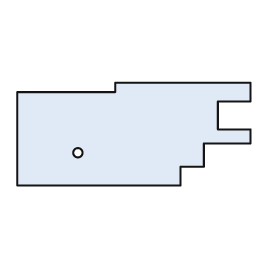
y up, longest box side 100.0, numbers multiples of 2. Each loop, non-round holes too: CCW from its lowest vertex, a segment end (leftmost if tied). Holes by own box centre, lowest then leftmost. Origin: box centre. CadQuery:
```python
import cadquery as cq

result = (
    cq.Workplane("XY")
    .moveTo(-50.0, -22.0)
    .lineTo(20.0, -22.0)
    .lineTo(20.0, -14.0)
    .lineTo(30.0, -14.0)
    .lineTo(30.0, -4.0)
    .lineTo(50.0, -4.0)
    .lineTo(50.0, 2.0)
    .lineTo(36.0, 2.0)
    .lineTo(36.0, 14.0)
    .lineTo(50.0, 14.0)
    .lineTo(50.0, 22.0)
    .lineTo(-8.0, 22.0)
    .lineTo(-8.0, 18.0)
    .lineTo(-50.0, 18.0)
    .close()
    .moveTo(-24.0, -8.0)
    .circle(2.0)
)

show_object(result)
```